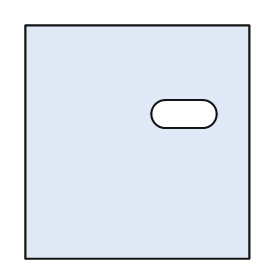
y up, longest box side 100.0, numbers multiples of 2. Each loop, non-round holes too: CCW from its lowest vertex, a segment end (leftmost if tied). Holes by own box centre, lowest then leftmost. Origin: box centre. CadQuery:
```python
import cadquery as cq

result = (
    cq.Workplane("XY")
    .moveTo(-48.0, -50.0)
    .lineTo(48.0, -50.0)
    .lineTo(48.0, 50.0)
    .lineTo(-48.0, 50.0)
    .close()
    .moveTo(12.0, 6.0)
    .lineTo(28.0, 6.0)
    .threePointArc((34.0, 12.0), (28.0, 18.0))
    .lineTo(12.0, 18.0)
    .threePointArc((6.0, 12.0), (12.0, 6.0))
    .close()
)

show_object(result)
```